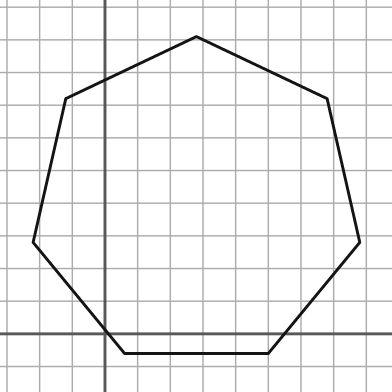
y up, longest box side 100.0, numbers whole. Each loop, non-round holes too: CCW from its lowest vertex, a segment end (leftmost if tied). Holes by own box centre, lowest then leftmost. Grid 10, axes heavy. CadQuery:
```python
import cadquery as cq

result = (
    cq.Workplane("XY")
    .moveTo(6.0, -6.0)
    .lineTo(50.0, -6.0)
    .lineTo(78.0, 28.0)
    .lineTo(68.0, 72.0)
    .lineTo(28.0, 91.0)
    .lineTo(-12.0, 72.0)
    .lineTo(-22.0, 28.0)
    .close()
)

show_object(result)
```